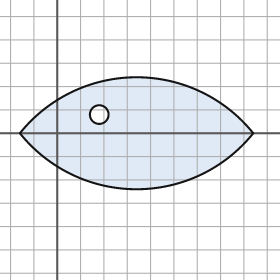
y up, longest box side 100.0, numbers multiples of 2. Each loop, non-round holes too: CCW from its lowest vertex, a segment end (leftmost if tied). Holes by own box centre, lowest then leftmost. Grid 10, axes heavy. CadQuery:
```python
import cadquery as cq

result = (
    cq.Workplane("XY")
    .moveTo(-16.0, 0.0)
    .threePointArc((34.0, -24.0), (84.0, 0.0))
    .threePointArc((34.0, 24.0), (-16.0, 0.0))
    .close()
    .moveTo(18.0, 8.0)
    .circle(4.0)
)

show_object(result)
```